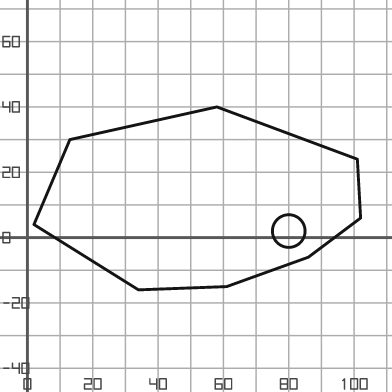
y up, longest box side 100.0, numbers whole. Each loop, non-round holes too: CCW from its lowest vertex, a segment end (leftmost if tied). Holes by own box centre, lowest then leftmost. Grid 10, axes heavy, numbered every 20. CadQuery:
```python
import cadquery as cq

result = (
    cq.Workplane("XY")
    .moveTo(34.0, -16.0)
    .lineTo(61.0, -15.0)
    .lineTo(86.0, -6.0)
    .lineTo(102.0, 6.0)
    .lineTo(101.0, 24.0)
    .lineTo(58.0, 40.0)
    .lineTo(13.0, 30.0)
    .lineTo(2.0, 4.0)
    .close()
    .moveTo(80.0, 2.0)
    .circle(5.0)
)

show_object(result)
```